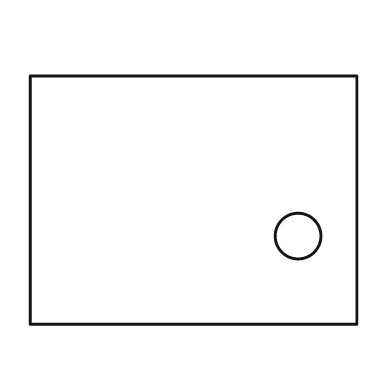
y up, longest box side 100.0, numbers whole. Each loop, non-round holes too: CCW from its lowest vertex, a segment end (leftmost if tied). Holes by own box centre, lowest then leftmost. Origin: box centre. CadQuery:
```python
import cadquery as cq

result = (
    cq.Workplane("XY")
    .moveTo(-50.0, -38.0)
    .lineTo(50.0, -38.0)
    .lineTo(50.0, 38.0)
    .lineTo(-50.0, 38.0)
    .close()
    .moveTo(32.0, -11.0)
    .circle(7.0)
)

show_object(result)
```